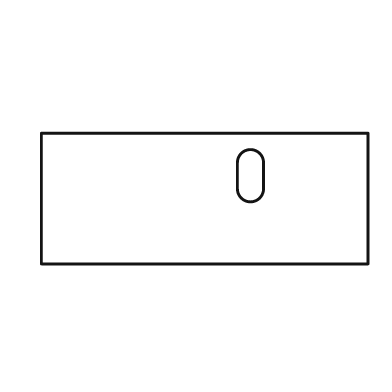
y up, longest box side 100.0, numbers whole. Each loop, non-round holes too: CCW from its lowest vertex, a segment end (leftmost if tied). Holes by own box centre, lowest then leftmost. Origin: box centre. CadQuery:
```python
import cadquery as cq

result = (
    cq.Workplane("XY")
    .moveTo(-50.0, -20.0)
    .lineTo(50.0, -20.0)
    .lineTo(50.0, 20.0)
    .lineTo(-50.0, 20.0)
    .close()
    .moveTo(10.0, 3.0)
    .threePointArc((14.0, -1.0), (18.0, 3.0))
    .lineTo(18.0, 11.0)
    .threePointArc((14.0, 15.0), (10.0, 11.0))
    .close()
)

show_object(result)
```